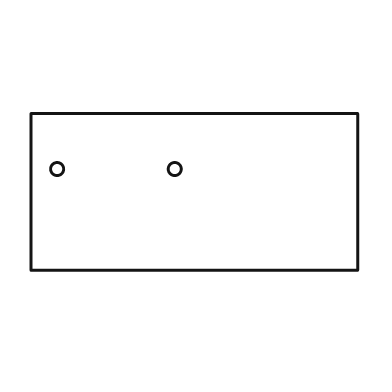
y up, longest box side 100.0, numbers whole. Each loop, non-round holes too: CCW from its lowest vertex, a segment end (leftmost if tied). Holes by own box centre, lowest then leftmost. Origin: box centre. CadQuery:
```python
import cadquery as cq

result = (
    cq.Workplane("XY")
    .moveTo(-50.0, -24.0)
    .lineTo(50.0, -24.0)
    .lineTo(50.0, 24.0)
    .lineTo(-50.0, 24.0)
    .close()
    .moveTo(-42.0, 7.0)
    .circle(2.0)
    .moveTo(-6.0, 7.0)
    .circle(2.0)
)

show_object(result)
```